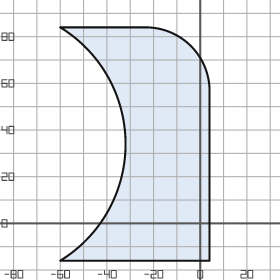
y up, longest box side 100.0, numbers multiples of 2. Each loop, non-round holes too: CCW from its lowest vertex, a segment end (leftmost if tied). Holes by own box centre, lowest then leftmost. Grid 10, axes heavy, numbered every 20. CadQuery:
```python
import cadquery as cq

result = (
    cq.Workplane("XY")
    .moveTo(-60.0, -16.0)
    .lineTo(4.0, -16.0)
    .lineTo(4.0, 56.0)
    .threePointArc((-4.0, 76.0), (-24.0, 84.0))
    .lineTo(-60.0, 84.0)
    .threePointArc((-32.0, 34.0), (-60.0, -16.0))
    .close()
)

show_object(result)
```